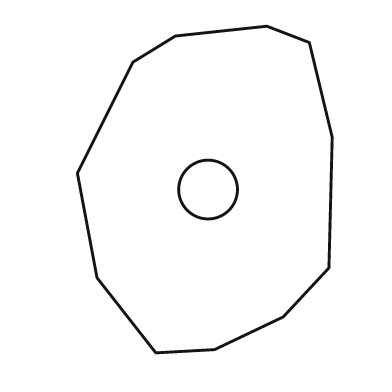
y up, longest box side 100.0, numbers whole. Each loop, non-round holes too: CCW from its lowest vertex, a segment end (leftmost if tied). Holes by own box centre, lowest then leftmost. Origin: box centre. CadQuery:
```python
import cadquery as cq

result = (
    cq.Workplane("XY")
    .moveTo(-15.0, -50.0)
    .lineTo(3.0, -49.0)
    .lineTo(24.0, -39.0)
    .lineTo(38.0, -24.0)
    .lineTo(39.0, 16.0)
    .lineTo(32.0, 45.0)
    .lineTo(19.0, 50.0)
    .lineTo(-9.0, 47.0)
    .lineTo(-22.0, 39.0)
    .lineTo(-39.0, 5.0)
    .lineTo(-33.0, -27.0)
    .close()
    .moveTo(1.0, 0.0)
    .circle(9.0)
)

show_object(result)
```